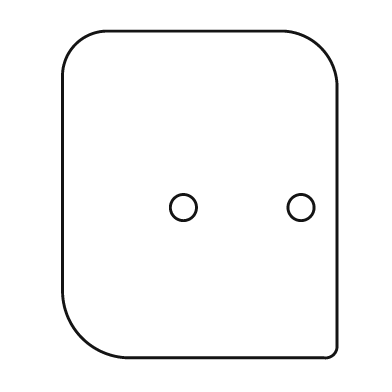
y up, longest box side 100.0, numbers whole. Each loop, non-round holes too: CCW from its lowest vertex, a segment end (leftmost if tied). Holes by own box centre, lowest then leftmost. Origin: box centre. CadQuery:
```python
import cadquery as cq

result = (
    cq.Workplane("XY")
    .moveTo(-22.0, -50.0)
    .lineTo(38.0, -50.0)
    .threePointArc((41.0, -49.0), (42.0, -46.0))
    .lineTo(42.0, 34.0)
    .threePointArc((37.0, 45.0), (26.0, 50.0))
    .lineTo(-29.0, 50.0)
    .threePointArc((-38.0, 46.0), (-42.0, 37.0))
    .lineTo(-42.0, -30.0)
    .threePointArc((-36.0, -44.0), (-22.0, -50.0))
    .close()
    .moveTo(-5.0, -4.0)
    .circle(4.0)
    .moveTo(31.0, -4.0)
    .circle(4.0)
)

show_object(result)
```